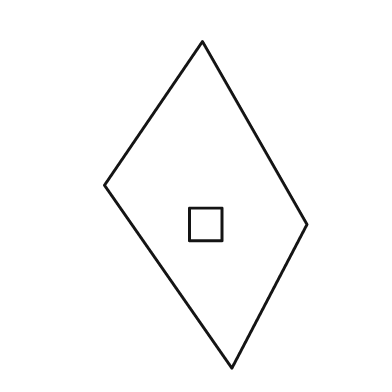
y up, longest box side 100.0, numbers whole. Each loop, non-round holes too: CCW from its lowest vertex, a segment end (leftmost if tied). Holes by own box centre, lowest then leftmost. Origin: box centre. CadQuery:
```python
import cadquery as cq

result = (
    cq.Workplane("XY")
    .moveTo(8.0, -50.0)
    .lineTo(31.0, -6.0)
    .lineTo(-1.0, 50.0)
    .lineTo(-31.0, 6.0)
    .close()
    .moveTo(-5.0, -11.0)
    .lineTo(5.0, -11.0)
    .lineTo(5.0, -1.0)
    .lineTo(-5.0, -1.0)
    .close()
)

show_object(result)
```